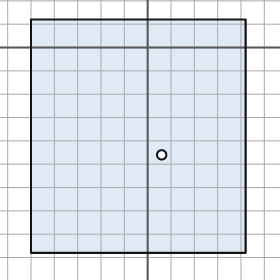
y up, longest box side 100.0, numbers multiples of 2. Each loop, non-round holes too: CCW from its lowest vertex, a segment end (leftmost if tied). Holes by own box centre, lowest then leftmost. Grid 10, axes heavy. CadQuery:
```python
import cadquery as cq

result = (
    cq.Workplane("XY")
    .moveTo(-50.0, -88.0)
    .lineTo(42.0, -88.0)
    .lineTo(42.0, 12.0)
    .lineTo(-50.0, 12.0)
    .close()
    .moveTo(6.0, -46.0)
    .circle(2.0)
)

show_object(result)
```